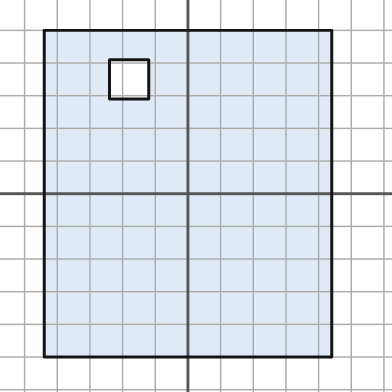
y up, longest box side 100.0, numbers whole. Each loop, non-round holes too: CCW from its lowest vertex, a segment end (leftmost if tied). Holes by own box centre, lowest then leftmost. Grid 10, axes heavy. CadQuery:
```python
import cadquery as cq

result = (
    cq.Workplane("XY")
    .moveTo(-44.0, -50.0)
    .lineTo(44.0, -50.0)
    .lineTo(44.0, 50.0)
    .lineTo(-44.0, 50.0)
    .close()
    .moveTo(-24.0, 29.0)
    .lineTo(-12.0, 29.0)
    .lineTo(-12.0, 41.0)
    .lineTo(-24.0, 41.0)
    .close()
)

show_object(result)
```